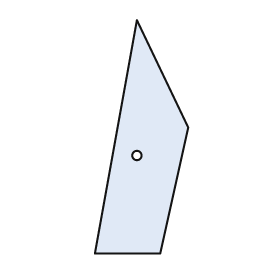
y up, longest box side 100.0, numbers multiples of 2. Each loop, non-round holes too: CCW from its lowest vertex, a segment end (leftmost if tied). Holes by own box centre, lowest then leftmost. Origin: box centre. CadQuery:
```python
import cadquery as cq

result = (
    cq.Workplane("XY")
    .moveTo(-20.0, -50.0)
    .lineTo(8.0, -50.0)
    .lineTo(20.0, 4.0)
    .lineTo(-2.0, 50.0)
    .close()
    .moveTo(-2.0, -8.0)
    .circle(2.0)
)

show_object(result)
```